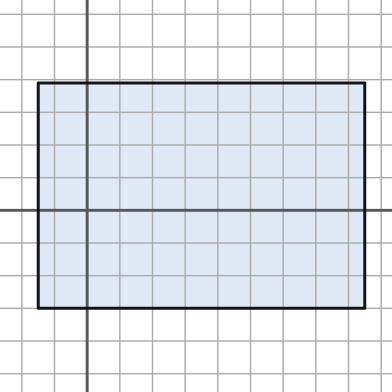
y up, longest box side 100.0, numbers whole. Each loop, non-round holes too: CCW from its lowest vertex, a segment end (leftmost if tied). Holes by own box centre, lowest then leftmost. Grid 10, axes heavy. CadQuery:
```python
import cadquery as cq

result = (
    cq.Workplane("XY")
    .moveTo(-15.0, -30.0)
    .lineTo(85.0, -30.0)
    .lineTo(85.0, 39.0)
    .lineTo(-15.0, 39.0)
    .close()
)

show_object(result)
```